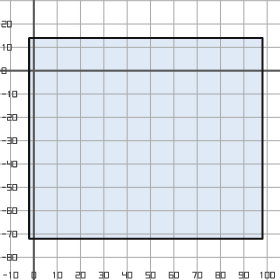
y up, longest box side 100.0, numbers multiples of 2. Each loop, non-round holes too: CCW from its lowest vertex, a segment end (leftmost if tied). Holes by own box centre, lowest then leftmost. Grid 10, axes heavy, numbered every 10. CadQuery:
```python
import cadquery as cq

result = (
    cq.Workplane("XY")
    .moveTo(-2.0, -72.0)
    .lineTo(98.0, -72.0)
    .lineTo(98.0, 14.0)
    .lineTo(-2.0, 14.0)
    .close()
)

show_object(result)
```